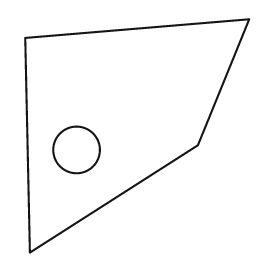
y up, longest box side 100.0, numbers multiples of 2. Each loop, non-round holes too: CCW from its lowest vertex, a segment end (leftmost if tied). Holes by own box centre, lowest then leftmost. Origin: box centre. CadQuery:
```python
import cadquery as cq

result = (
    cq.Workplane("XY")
    .moveTo(-46.0, -50.0)
    .lineTo(26.0, -4.0)
    .lineTo(48.0, 50.0)
    .lineTo(-48.0, 42.0)
    .close()
    .moveTo(-26.0, -6.0)
    .circle(10.0)
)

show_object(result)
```